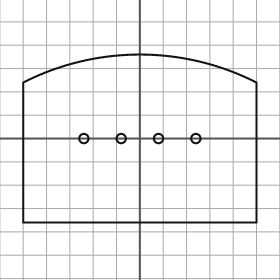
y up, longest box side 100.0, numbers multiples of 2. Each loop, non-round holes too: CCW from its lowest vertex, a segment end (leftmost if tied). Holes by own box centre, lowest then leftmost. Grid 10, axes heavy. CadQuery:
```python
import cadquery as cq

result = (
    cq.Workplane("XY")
    .moveTo(-50.0, -36.0)
    .lineTo(50.0, -36.0)
    .lineTo(50.0, 24.0)
    .threePointArc((0.0, 36.0), (-50.0, 24.0))
    .close()
    .moveTo(-24.0, 0.0)
    .circle(2.0)
    .moveTo(-8.0, 0.0)
    .circle(2.0)
    .moveTo(8.0, 0.0)
    .circle(2.0)
    .moveTo(24.0, 0.0)
    .circle(2.0)
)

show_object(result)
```